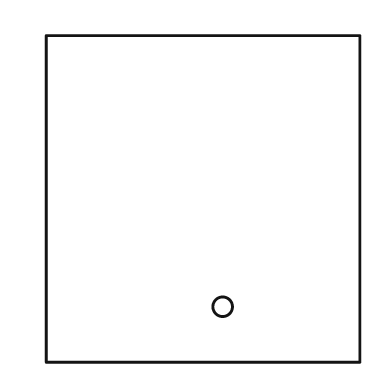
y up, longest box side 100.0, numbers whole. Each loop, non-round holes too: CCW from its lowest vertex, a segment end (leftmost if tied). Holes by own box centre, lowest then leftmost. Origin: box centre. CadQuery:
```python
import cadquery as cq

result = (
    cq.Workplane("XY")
    .moveTo(-48.0, -50.0)
    .lineTo(48.0, -50.0)
    .lineTo(48.0, 50.0)
    .lineTo(-48.0, 50.0)
    .close()
    .moveTo(6.0, -33.0)
    .circle(3.0)
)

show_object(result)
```